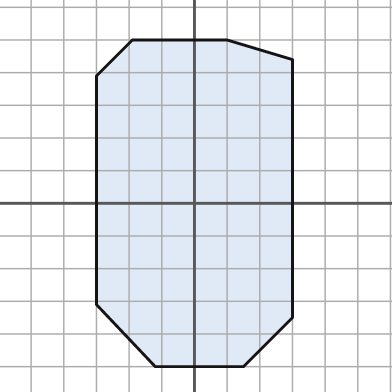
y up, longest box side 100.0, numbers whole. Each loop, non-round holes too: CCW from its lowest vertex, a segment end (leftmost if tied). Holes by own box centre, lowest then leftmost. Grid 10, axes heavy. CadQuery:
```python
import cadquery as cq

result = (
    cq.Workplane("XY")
    .moveTo(-12.0, -50.0)
    .lineTo(15.0, -50.0)
    .lineTo(30.0, -35.0)
    .lineTo(30.0, 44.0)
    .lineTo(10.0, 50.0)
    .lineTo(-19.0, 50.0)
    .lineTo(-30.0, 39.0)
    .lineTo(-30.0, -31.0)
    .close()
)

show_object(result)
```